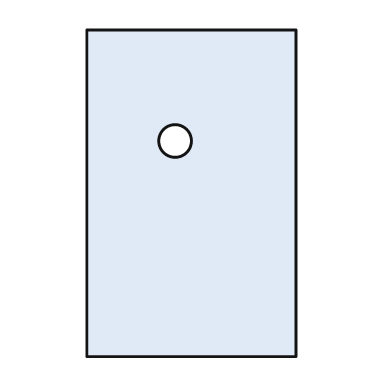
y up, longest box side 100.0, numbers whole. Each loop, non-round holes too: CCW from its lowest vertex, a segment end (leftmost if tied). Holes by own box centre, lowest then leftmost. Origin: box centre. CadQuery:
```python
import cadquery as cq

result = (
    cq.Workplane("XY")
    .moveTo(-32.0, -50.0)
    .lineTo(32.0, -50.0)
    .lineTo(32.0, 50.0)
    .lineTo(-32.0, 50.0)
    .close()
    .moveTo(-5.0, 16.0)
    .circle(5.0)
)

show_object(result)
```